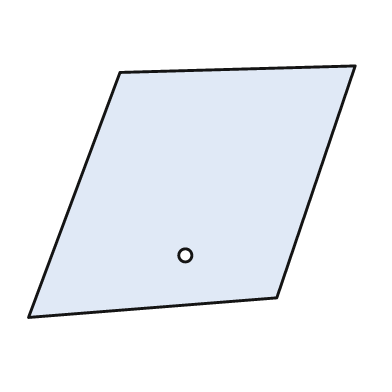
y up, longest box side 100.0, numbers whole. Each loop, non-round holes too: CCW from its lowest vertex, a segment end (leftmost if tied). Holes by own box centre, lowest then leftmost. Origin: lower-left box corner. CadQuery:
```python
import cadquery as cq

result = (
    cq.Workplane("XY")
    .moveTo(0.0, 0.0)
    .lineTo(76.0, 6.0)
    .lineTo(100.0, 77.0)
    .lineTo(28.0, 75.0)
    .close()
    .moveTo(48.0, 19.0)
    .circle(2.0)
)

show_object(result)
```